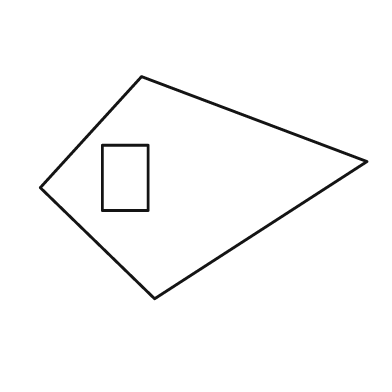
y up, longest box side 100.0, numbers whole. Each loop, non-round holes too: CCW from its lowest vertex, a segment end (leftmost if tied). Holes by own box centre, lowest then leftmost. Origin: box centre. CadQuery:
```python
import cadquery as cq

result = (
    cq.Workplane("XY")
    .moveTo(-15.0, -34.0)
    .lineTo(50.0, 8.0)
    .lineTo(-19.0, 34.0)
    .lineTo(-50.0, 0.0)
    .close()
    .moveTo(-31.0, -7.0)
    .lineTo(-17.0, -7.0)
    .lineTo(-17.0, 13.0)
    .lineTo(-31.0, 13.0)
    .close()
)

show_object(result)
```